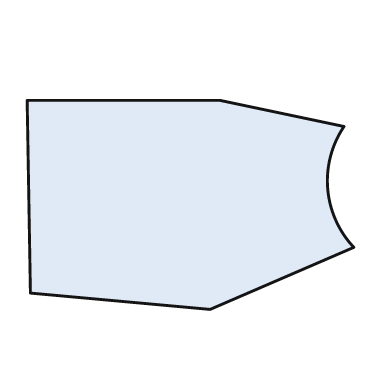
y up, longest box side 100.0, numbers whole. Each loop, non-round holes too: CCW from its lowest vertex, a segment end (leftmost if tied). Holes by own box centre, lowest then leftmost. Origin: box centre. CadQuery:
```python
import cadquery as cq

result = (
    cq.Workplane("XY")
    .moveTo(6.0, -32.0)
    .lineTo(50.0, -13.0)
    .threePointArc((42.0, 5.0), (47.0, 24.0))
    .lineTo(9.0, 32.0)
    .lineTo(-50.0, 32.0)
    .lineTo(-49.0, -27.0)
    .close()
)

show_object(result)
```